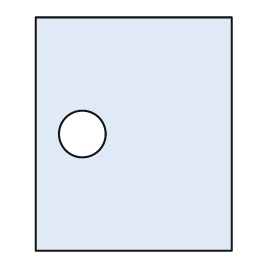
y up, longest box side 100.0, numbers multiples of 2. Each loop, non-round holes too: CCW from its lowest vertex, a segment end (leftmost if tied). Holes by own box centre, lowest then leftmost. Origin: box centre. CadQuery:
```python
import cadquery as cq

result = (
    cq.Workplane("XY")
    .moveTo(-42.0, -50.0)
    .lineTo(42.0, -50.0)
    .lineTo(42.0, 50.0)
    .lineTo(-42.0, 50.0)
    .close()
    .moveTo(-22.0, 0.0)
    .circle(10.0)
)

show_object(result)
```